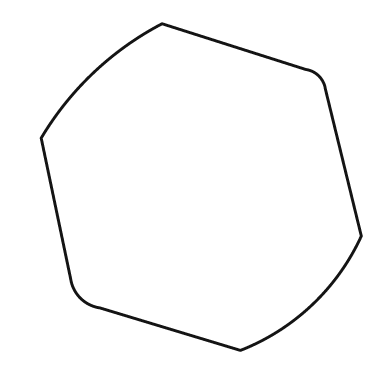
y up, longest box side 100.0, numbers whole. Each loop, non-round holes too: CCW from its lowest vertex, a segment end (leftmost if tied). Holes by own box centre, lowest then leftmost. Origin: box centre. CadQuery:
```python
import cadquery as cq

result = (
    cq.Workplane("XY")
    .moveTo(12.0, -50.0)
    .threePointArc((34.0, -36.0), (49.0, -15.0))
    .lineTo(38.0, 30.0)
    .threePointArc((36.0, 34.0), (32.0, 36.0))
    .lineTo(-12.0, 50.0)
    .threePointArc((-33.0, 35.0), (-49.0, 15.0))
    .lineTo(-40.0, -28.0)
    .threePointArc((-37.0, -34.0), (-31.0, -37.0))
    .close()
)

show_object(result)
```